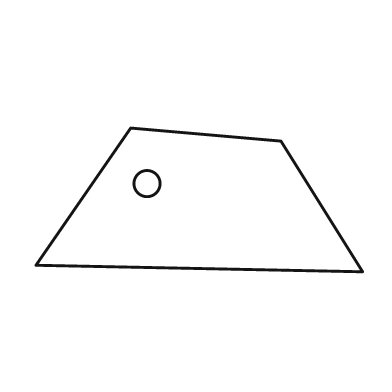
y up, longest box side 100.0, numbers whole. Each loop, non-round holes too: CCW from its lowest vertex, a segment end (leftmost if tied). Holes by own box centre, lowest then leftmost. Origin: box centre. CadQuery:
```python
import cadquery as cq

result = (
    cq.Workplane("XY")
    .moveTo(50.0, -22.0)
    .lineTo(25.0, 18.0)
    .lineTo(-21.0, 22.0)
    .lineTo(-50.0, -20.0)
    .close()
    .moveTo(-16.0, 5.0)
    .circle(4.0)
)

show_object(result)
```